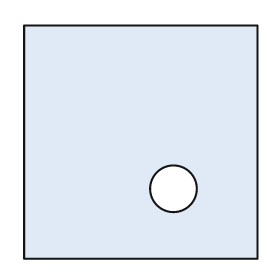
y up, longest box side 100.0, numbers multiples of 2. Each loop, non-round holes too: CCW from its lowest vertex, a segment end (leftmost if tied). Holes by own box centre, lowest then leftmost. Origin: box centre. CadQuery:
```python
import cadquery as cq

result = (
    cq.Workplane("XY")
    .moveTo(-50.0, -50.0)
    .lineTo(50.0, -50.0)
    .lineTo(50.0, 50.0)
    .lineTo(-50.0, 50.0)
    .close()
    .moveTo(14.0, -20.0)
    .circle(10.0)
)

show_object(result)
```